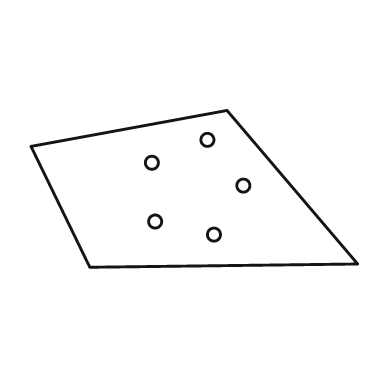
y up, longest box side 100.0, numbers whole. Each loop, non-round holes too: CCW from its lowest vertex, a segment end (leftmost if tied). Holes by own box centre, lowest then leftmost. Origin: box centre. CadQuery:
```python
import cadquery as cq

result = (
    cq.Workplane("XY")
    .moveTo(-32.0, -24.0)
    .lineTo(50.0, -23.0)
    .lineTo(10.0, 24.0)
    .lineTo(-50.0, 13.0)
    .close()
    .moveTo(6.0, -14.0)
    .circle(2.0)
    .moveTo(-12.0, -10.0)
    .circle(2.0)
    .moveTo(15.0, 1.0)
    .circle(2.0)
    .moveTo(-13.0, 8.0)
    .circle(2.0)
    .moveTo(4.0, 15.0)
    .circle(2.0)
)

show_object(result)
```